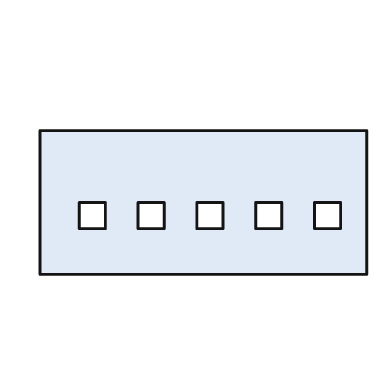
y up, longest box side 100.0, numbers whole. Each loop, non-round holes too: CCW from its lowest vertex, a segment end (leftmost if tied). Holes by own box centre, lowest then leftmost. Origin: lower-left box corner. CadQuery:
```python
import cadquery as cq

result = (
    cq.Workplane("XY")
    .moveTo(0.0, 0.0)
    .lineTo(100.0, 0.0)
    .lineTo(100.0, 44.0)
    .lineTo(0.0, 44.0)
    .close()
    .moveTo(12.0, 14.0)
    .lineTo(20.0, 14.0)
    .lineTo(20.0, 22.0)
    .lineTo(12.0, 22.0)
    .close()
    .moveTo(30.0, 14.0)
    .lineTo(38.0, 14.0)
    .lineTo(38.0, 22.0)
    .lineTo(30.0, 22.0)
    .close()
    .moveTo(48.0, 14.0)
    .lineTo(56.0, 14.0)
    .lineTo(56.0, 22.0)
    .lineTo(48.0, 22.0)
    .close()
    .moveTo(66.0, 14.0)
    .lineTo(74.0, 14.0)
    .lineTo(74.0, 22.0)
    .lineTo(66.0, 22.0)
    .close()
    .moveTo(84.0, 14.0)
    .lineTo(92.0, 14.0)
    .lineTo(92.0, 22.0)
    .lineTo(84.0, 22.0)
    .close()
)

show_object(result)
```